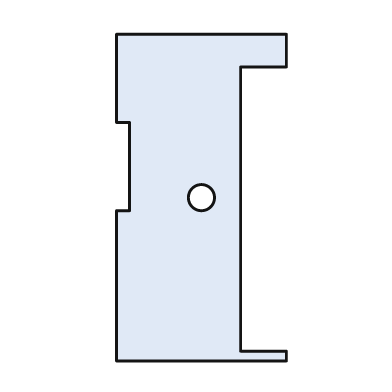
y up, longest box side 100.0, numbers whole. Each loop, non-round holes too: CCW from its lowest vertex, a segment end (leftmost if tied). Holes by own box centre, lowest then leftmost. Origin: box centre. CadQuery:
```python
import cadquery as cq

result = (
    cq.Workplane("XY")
    .moveTo(-26.0, -50.0)
    .lineTo(26.0, -50.0)
    .lineTo(26.0, -47.0)
    .lineTo(12.0, -47.0)
    .lineTo(12.0, 40.0)
    .lineTo(26.0, 40.0)
    .lineTo(26.0, 50.0)
    .lineTo(-26.0, 50.0)
    .lineTo(-26.0, 23.0)
    .lineTo(-22.0, 23.0)
    .lineTo(-22.0, -4.0)
    .lineTo(-26.0, -4.0)
    .close()
    .moveTo(0.0, 0.0)
    .circle(4.0)
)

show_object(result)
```